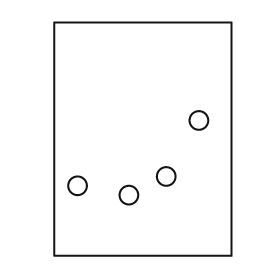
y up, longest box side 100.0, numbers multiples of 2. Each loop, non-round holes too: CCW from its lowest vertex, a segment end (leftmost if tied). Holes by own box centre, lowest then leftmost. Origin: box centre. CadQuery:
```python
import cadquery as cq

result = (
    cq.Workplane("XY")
    .moveTo(-38.0, -50.0)
    .lineTo(38.0, -50.0)
    .lineTo(38.0, 50.0)
    .lineTo(-38.0, 50.0)
    .close()
    .moveTo(-6.0, -24.0)
    .circle(4.0)
    .moveTo(-28.0, -20.0)
    .circle(4.0)
    .moveTo(10.0, -16.0)
    .circle(4.0)
    .moveTo(24.0, 8.0)
    .circle(4.0)
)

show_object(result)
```